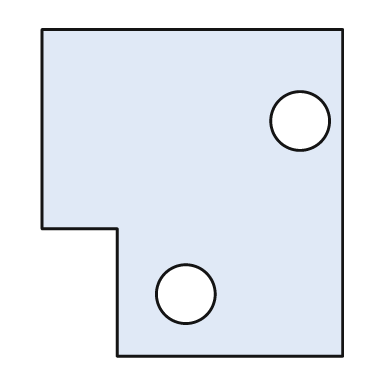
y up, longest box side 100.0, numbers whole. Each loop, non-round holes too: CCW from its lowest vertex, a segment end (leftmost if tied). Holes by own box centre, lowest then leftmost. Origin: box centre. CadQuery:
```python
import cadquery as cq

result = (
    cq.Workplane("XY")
    .moveTo(-23.0, -50.0)
    .lineTo(46.0, -50.0)
    .lineTo(46.0, 50.0)
    .lineTo(-46.0, 50.0)
    .lineTo(-46.0, -11.0)
    .lineTo(-23.0, -11.0)
    .close()
    .moveTo(-2.0, -31.0)
    .circle(9.0)
    .moveTo(33.0, 22.0)
    .circle(9.0)
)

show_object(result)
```